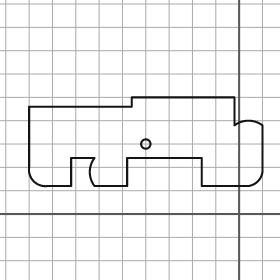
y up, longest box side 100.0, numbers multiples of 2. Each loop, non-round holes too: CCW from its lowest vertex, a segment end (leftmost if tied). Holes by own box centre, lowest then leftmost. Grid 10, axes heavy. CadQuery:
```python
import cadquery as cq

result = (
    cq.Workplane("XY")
    .moveTo(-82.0, 12.0)
    .lineTo(-72.0, 12.0)
    .lineTo(-72.0, 24.0)
    .lineTo(-62.0, 24.0)
    .threePointArc((-64.0, 18.0), (-62.0, 12.0))
    .lineTo(-48.0, 12.0)
    .lineTo(-48.0, 24.0)
    .lineTo(-16.0, 24.0)
    .lineTo(-16.0, 12.0)
    .lineTo(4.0, 12.0)
    .threePointArc((8.0, 14.0), (10.0, 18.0))
    .lineTo(10.0, 38.0)
    .threePointArc((4.0, 40.0), (-2.0, 38.0))
    .lineTo(-2.0, 50.0)
    .lineTo(-46.0, 50.0)
    .lineTo(-46.0, 46.0)
    .lineTo(-90.0, 46.0)
    .lineTo(-90.0, 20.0)
    .threePointArc((-88.0, 14.0), (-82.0, 12.0))
    .close()
    .moveTo(-40.0, 30.0)
    .circle(2.0)
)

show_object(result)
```